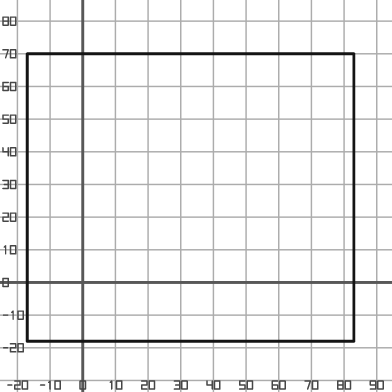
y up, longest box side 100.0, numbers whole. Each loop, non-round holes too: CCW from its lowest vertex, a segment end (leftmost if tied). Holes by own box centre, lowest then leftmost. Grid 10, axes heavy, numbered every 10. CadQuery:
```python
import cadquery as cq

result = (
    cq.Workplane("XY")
    .moveTo(-17.0, -18.0)
    .lineTo(83.0, -18.0)
    .lineTo(83.0, 70.0)
    .lineTo(-17.0, 70.0)
    .close()
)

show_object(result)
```